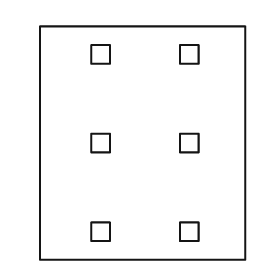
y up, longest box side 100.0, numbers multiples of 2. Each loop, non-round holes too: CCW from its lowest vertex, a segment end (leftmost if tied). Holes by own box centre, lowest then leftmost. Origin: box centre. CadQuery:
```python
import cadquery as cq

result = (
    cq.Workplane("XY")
    .moveTo(-44.0, -50.0)
    .lineTo(44.0, -50.0)
    .lineTo(44.0, 50.0)
    .lineTo(-44.0, 50.0)
    .close()
    .moveTo(-22.0, -42.0)
    .lineTo(-14.0, -42.0)
    .lineTo(-14.0, -34.0)
    .lineTo(-22.0, -34.0)
    .close()
    .moveTo(16.0, -42.0)
    .lineTo(24.0, -42.0)
    .lineTo(24.0, -34.0)
    .lineTo(16.0, -34.0)
    .close()
    .moveTo(-22.0, -4.0)
    .lineTo(-14.0, -4.0)
    .lineTo(-14.0, 4.0)
    .lineTo(-22.0, 4.0)
    .close()
    .moveTo(16.0, -4.0)
    .lineTo(24.0, -4.0)
    .lineTo(24.0, 4.0)
    .lineTo(16.0, 4.0)
    .close()
    .moveTo(-22.0, 34.0)
    .lineTo(-14.0, 34.0)
    .lineTo(-14.0, 42.0)
    .lineTo(-22.0, 42.0)
    .close()
    .moveTo(16.0, 34.0)
    .lineTo(24.0, 34.0)
    .lineTo(24.0, 42.0)
    .lineTo(16.0, 42.0)
    .close()
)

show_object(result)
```